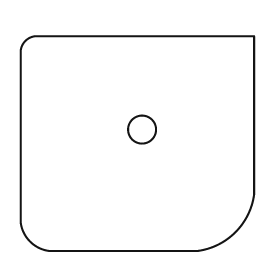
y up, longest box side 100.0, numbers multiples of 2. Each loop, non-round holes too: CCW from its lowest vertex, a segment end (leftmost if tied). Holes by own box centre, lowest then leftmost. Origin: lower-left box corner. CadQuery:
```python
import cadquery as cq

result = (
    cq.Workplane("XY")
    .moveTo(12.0, 0.0)
    .lineTo(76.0, 0.0)
    .threePointArc((92.0, 8.0), (100.0, 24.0))
    .lineTo(100.0, 92.0)
    .lineTo(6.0, 92.0)
    .threePointArc((2.0, 90.0), (0.0, 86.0))
    .lineTo(0.0, 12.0)
    .threePointArc((4.0, 4.0), (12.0, 0.0))
    .close()
    .moveTo(52.0, 52.0)
    .circle(6.0)
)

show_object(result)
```